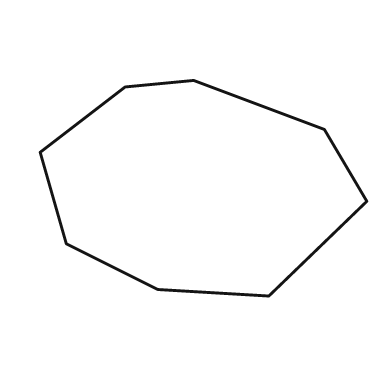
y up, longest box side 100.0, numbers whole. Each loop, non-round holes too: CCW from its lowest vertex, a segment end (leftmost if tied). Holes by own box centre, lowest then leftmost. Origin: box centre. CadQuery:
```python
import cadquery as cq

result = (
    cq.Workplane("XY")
    .moveTo(20.0, -33.0)
    .lineTo(50.0, -4.0)
    .lineTo(37.0, 18.0)
    .lineTo(-3.0, 33.0)
    .lineTo(-24.0, 31.0)
    .lineTo(-50.0, 11.0)
    .lineTo(-42.0, -17.0)
    .lineTo(-14.0, -31.0)
    .close()
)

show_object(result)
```